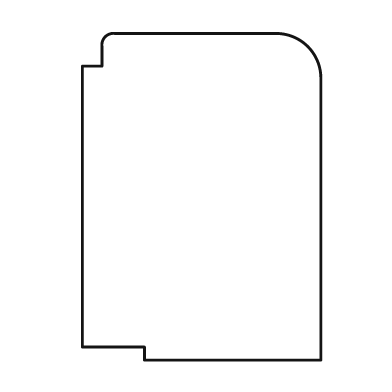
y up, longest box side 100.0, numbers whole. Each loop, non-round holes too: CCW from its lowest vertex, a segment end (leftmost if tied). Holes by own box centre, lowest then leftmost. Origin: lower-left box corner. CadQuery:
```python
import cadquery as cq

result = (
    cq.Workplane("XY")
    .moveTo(19.0, 0.0)
    .lineTo(73.0, 0.0)
    .lineTo(73.0, 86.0)
    .threePointArc((69.0, 96.0), (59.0, 100.0))
    .lineTo(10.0, 100.0)
    .threePointArc((7.0, 99.0), (6.0, 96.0))
    .lineTo(6.0, 90.0)
    .lineTo(0.0, 90.0)
    .lineTo(0.0, 4.0)
    .lineTo(19.0, 4.0)
    .close()
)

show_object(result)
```